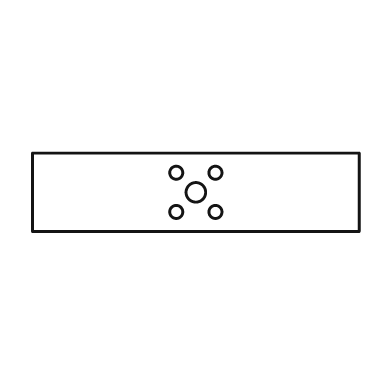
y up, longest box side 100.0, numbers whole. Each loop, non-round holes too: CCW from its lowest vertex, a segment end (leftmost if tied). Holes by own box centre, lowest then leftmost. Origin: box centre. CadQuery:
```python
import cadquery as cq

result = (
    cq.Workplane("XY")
    .moveTo(-50.0, -12.0)
    .lineTo(50.0, -12.0)
    .lineTo(50.0, 12.0)
    .lineTo(-50.0, 12.0)
    .close()
    .moveTo(-6.0, -6.0)
    .circle(2.0)
    .moveTo(6.0, -6.0)
    .circle(2.0)
    .moveTo(0.0, 0.0)
    .circle(3.0)
    .moveTo(-6.0, 6.0)
    .circle(2.0)
    .moveTo(6.0, 6.0)
    .circle(2.0)
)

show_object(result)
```